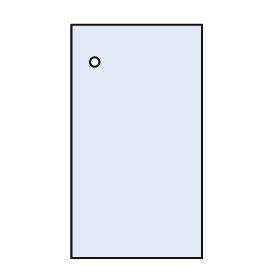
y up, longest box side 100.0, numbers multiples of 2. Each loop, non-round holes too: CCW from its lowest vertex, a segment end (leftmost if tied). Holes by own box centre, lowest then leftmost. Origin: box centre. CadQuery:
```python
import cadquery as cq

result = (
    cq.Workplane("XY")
    .moveTo(-28.0, -50.0)
    .lineTo(28.0, -50.0)
    .lineTo(28.0, 50.0)
    .lineTo(-28.0, 50.0)
    .close()
    .moveTo(-18.0, 34.0)
    .circle(2.0)
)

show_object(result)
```